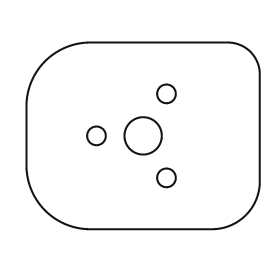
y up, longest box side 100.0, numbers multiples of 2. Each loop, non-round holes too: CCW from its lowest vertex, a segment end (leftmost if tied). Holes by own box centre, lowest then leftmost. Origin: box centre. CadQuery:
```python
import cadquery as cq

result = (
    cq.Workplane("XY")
    .moveTo(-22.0, -40.0)
    .lineTo(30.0, -40.0)
    .threePointArc((44.0, -34.0), (50.0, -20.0))
    .lineTo(50.0, 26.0)
    .threePointArc((46.0, 36.0), (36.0, 40.0))
    .lineTo(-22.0, 40.0)
    .threePointArc((-42.0, 32.0), (-50.0, 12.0))
    .lineTo(-50.0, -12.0)
    .threePointArc((-42.0, -32.0), (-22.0, -40.0))
    .close()
    .moveTo(10.0, -18.0)
    .circle(4.0)
    .moveTo(-20.0, 0.0)
    .circle(4.0)
    .moveTo(0.0, 0.0)
    .circle(8.0)
    .moveTo(10.0, 18.0)
    .circle(4.0)
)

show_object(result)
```